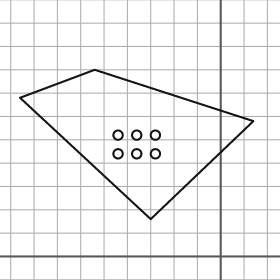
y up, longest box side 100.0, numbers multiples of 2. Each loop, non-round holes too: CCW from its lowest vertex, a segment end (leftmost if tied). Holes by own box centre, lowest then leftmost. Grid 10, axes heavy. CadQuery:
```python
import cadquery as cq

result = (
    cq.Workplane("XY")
    .moveTo(-30.0, 16.0)
    .lineTo(14.0, 58.0)
    .lineTo(-54.0, 80.0)
    .lineTo(-86.0, 68.0)
    .close()
    .moveTo(-44.0, 44.0)
    .circle(2.0)
    .moveTo(-36.0, 44.0)
    .circle(2.0)
    .moveTo(-28.0, 44.0)
    .circle(2.0)
    .moveTo(-44.0, 52.0)
    .circle(2.0)
    .moveTo(-36.0, 52.0)
    .circle(2.0)
    .moveTo(-28.0, 52.0)
    .circle(2.0)
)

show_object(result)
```